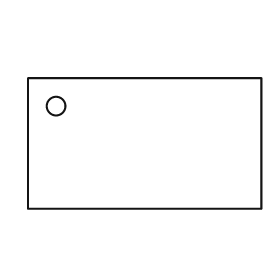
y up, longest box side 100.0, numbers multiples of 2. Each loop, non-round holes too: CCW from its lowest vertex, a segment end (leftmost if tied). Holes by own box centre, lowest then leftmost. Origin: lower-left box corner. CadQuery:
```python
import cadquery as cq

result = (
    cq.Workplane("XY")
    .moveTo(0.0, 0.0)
    .lineTo(100.0, 0.0)
    .lineTo(100.0, 56.0)
    .lineTo(0.0, 56.0)
    .close()
    .moveTo(12.0, 44.0)
    .circle(4.0)
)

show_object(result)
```